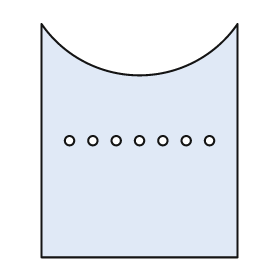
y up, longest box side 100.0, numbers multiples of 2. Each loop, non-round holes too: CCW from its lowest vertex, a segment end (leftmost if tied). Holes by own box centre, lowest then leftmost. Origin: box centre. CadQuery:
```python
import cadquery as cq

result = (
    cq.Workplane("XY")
    .moveTo(-42.0, -50.0)
    .lineTo(42.0, -50.0)
    .lineTo(42.0, 50.0)
    .threePointArc((0.0, 28.0), (-42.0, 50.0))
    .close()
    .moveTo(-30.0, 0.0)
    .circle(2.0)
    .moveTo(-20.0, 0.0)
    .circle(2.0)
    .moveTo(-10.0, 0.0)
    .circle(2.0)
    .moveTo(0.0, 0.0)
    .circle(2.0)
    .moveTo(10.0, 0.0)
    .circle(2.0)
    .moveTo(20.0, 0.0)
    .circle(2.0)
    .moveTo(30.0, 0.0)
    .circle(2.0)
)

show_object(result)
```